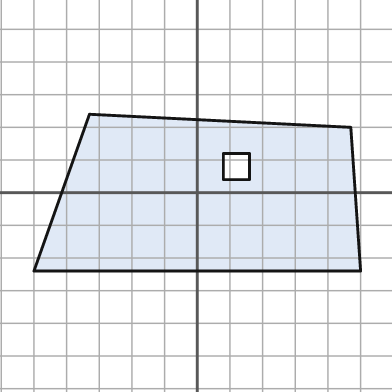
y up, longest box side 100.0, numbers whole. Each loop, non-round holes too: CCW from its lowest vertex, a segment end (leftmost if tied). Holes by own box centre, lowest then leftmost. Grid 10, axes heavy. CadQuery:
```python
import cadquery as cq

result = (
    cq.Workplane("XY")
    .moveTo(-50.0, -24.0)
    .lineTo(50.0, -24.0)
    .lineTo(47.0, 20.0)
    .lineTo(-33.0, 24.0)
    .close()
    .moveTo(8.0, 4.0)
    .lineTo(16.0, 4.0)
    .lineTo(16.0, 12.0)
    .lineTo(8.0, 12.0)
    .close()
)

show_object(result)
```